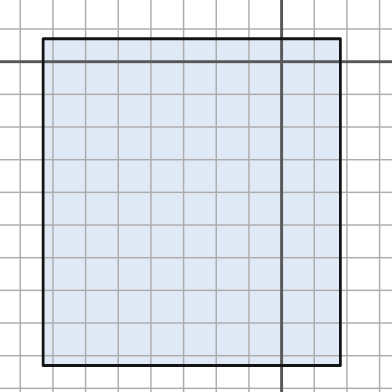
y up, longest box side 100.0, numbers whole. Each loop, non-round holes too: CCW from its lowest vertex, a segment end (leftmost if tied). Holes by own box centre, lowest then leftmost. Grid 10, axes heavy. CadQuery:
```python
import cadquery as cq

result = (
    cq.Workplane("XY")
    .moveTo(-73.0, -93.0)
    .lineTo(18.0, -93.0)
    .lineTo(18.0, 7.0)
    .lineTo(-73.0, 7.0)
    .close()
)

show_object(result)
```